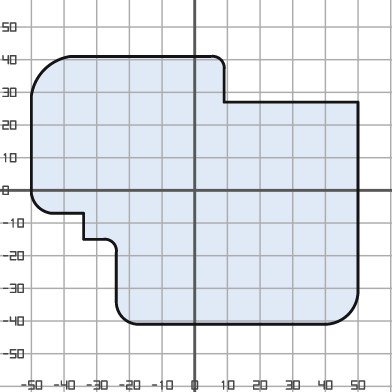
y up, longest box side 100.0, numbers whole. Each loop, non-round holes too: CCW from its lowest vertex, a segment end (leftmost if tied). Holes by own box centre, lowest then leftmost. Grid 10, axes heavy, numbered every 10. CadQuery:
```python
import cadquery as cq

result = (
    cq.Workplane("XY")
    .moveTo(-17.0, -41.0)
    .lineTo(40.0, -41.0)
    .threePointArc((47.0, -38.0), (50.0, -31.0))
    .lineTo(50.0, 27.0)
    .lineTo(9.0, 27.0)
    .lineTo(9.0, 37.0)
    .threePointArc((8.0, 40.0), (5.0, 41.0))
    .lineTo(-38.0, 41.0)
    .threePointArc((-46.0, 37.0), (-50.0, 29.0))
    .lineTo(-50.0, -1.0)
    .threePointArc((-48.0, -5.0), (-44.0, -7.0))
    .lineTo(-34.0, -7.0)
    .lineTo(-34.0, -15.0)
    .lineTo(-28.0, -15.0)
    .threePointArc((-25.0, -16.0), (-24.0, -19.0))
    .lineTo(-24.0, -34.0)
    .threePointArc((-22.0, -39.0), (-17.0, -41.0))
    .close()
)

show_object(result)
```